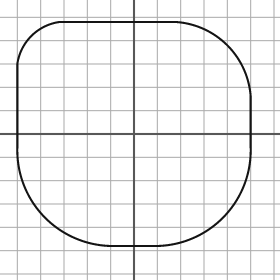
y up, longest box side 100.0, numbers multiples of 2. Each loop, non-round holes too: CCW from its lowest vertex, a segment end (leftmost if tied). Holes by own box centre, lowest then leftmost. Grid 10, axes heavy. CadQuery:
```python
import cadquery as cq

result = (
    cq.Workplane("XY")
    .moveTo(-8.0, -48.0)
    .lineTo(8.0, -48.0)
    .threePointArc((38.0, -36.0), (50.0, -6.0))
    .lineTo(50.0, 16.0)
    .threePointArc((40.0, 38.0), (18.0, 48.0))
    .lineTo(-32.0, 48.0)
    .threePointArc((-44.0, 42.0), (-50.0, 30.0))
    .lineTo(-50.0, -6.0)
    .threePointArc((-38.0, -36.0), (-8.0, -48.0))
    .close()
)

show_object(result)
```